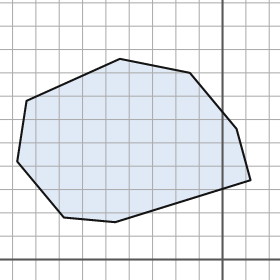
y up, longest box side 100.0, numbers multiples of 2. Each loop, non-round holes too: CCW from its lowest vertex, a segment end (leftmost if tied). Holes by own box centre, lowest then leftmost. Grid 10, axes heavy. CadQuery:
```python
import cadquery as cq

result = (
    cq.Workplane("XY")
    .moveTo(-46.0, 16.0)
    .lineTo(12.0, 34.0)
    .lineTo(6.0, 56.0)
    .lineTo(-14.0, 80.0)
    .lineTo(-44.0, 86.0)
    .lineTo(-84.0, 68.0)
    .lineTo(-88.0, 42.0)
    .lineTo(-68.0, 18.0)
    .close()
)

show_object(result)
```